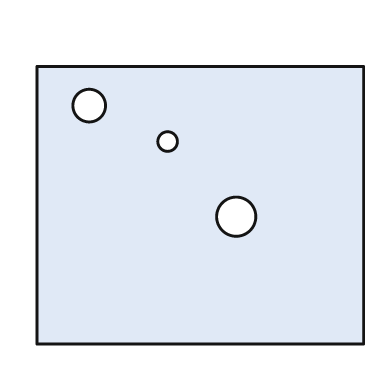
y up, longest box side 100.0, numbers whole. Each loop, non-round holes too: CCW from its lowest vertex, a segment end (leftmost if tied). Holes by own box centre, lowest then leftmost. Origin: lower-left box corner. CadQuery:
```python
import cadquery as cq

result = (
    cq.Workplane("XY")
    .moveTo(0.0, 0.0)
    .lineTo(100.0, 0.0)
    .lineTo(100.0, 85.0)
    .lineTo(0.0, 85.0)
    .close()
    .moveTo(61.0, 39.0)
    .circle(6.0)
    .moveTo(40.0, 62.0)
    .circle(3.0)
    .moveTo(16.0, 73.0)
    .circle(5.0)
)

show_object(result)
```